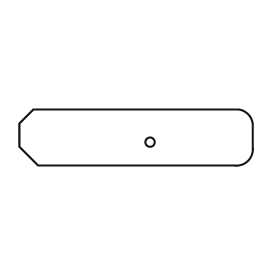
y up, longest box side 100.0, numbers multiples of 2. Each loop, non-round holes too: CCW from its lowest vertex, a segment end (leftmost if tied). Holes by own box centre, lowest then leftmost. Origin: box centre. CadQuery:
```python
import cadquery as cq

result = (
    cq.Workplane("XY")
    .moveTo(-42.0, -12.0)
    .lineTo(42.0, -12.0)
    .threePointArc((48.0, -10.0), (50.0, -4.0))
    .lineTo(50.0, 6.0)
    .threePointArc((48.0, 10.0), (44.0, 12.0))
    .lineTo(-44.0, 12.0)
    .lineTo(-50.0, 6.0)
    .lineTo(-50.0, -4.0)
    .close()
    .moveTo(6.0, -2.0)
    .circle(2.0)
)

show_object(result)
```